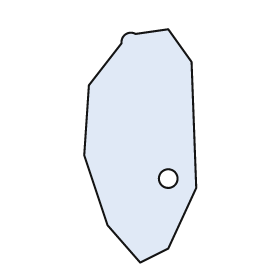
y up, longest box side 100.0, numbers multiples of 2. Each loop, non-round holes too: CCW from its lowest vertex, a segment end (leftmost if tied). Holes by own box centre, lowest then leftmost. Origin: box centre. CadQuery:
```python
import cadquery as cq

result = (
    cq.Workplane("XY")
    .moveTo(0.0, -50.0)
    .lineTo(12.0, -44.0)
    .lineTo(24.0, -18.0)
    .lineTo(22.0, 36.0)
    .lineTo(12.0, 50.0)
    .lineTo(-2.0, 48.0)
    .threePointArc((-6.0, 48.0), (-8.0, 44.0))
    .lineTo(-22.0, 26.0)
    .lineTo(-24.0, -4.0)
    .lineTo(-14.0, -34.0)
    .close()
    .moveTo(12.0, -14.0)
    .circle(4.0)
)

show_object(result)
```